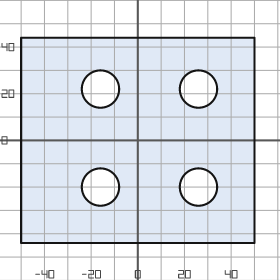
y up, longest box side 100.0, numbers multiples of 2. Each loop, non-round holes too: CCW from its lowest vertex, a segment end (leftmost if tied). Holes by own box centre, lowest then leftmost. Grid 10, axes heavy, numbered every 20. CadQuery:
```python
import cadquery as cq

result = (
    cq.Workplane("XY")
    .moveTo(-50.0, -44.0)
    .lineTo(50.0, -44.0)
    .lineTo(50.0, 44.0)
    .lineTo(-50.0, 44.0)
    .close()
    .moveTo(-16.0, -20.0)
    .circle(8.0)
    .moveTo(26.0, -20.0)
    .circle(8.0)
    .moveTo(-16.0, 22.0)
    .circle(8.0)
    .moveTo(26.0, 22.0)
    .circle(8.0)
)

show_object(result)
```